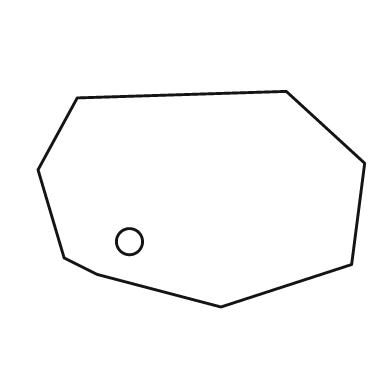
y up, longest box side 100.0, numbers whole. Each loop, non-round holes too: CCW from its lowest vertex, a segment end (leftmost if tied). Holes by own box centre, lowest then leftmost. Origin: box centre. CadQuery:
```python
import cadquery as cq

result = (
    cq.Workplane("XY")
    .moveTo(6.0, -33.0)
    .lineTo(46.0, -20.0)
    .lineTo(50.0, 11.0)
    .lineTo(26.0, 33.0)
    .lineTo(-38.0, 31.0)
    .lineTo(-50.0, 9.0)
    .lineTo(-42.0, -18.0)
    .lineTo(-32.0, -23.0)
    .close()
    .moveTo(-22.0, -13.0)
    .circle(4.0)
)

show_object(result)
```